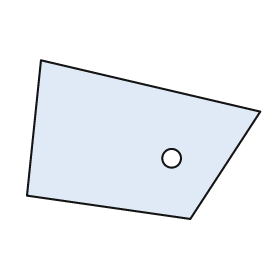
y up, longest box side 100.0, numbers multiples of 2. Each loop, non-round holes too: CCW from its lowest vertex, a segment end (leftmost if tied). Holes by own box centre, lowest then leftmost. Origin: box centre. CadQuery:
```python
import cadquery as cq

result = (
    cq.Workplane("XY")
    .moveTo(20.0, -34.0)
    .lineTo(50.0, 12.0)
    .lineTo(-44.0, 34.0)
    .lineTo(-50.0, -24.0)
    .close()
    .moveTo(12.0, -8.0)
    .circle(4.0)
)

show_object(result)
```